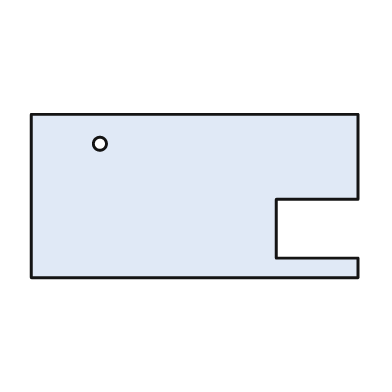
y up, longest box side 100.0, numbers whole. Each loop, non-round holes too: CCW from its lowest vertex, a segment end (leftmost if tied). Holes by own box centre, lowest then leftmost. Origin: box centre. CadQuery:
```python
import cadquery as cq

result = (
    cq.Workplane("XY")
    .moveTo(-50.0, -25.0)
    .lineTo(50.0, -25.0)
    .lineTo(50.0, -19.0)
    .lineTo(25.0, -19.0)
    .lineTo(25.0, -1.0)
    .lineTo(50.0, -1.0)
    .lineTo(50.0, 25.0)
    .lineTo(-50.0, 25.0)
    .close()
    .moveTo(-29.0, 16.0)
    .circle(2.0)
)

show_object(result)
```